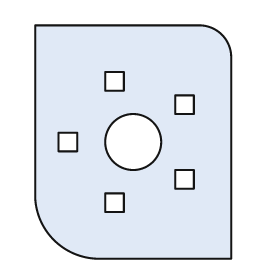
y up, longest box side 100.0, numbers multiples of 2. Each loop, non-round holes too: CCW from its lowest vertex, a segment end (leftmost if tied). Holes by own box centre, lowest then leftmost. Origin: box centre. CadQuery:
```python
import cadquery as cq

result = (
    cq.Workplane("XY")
    .moveTo(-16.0, -50.0)
    .lineTo(42.0, -50.0)
    .lineTo(42.0, 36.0)
    .threePointArc((38.0, 46.0), (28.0, 50.0))
    .lineTo(-42.0, 50.0)
    .lineTo(-42.0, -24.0)
    .threePointArc((-34.0, -42.0), (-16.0, -50.0))
    .close()
    .moveTo(-12.0, -30.0)
    .lineTo(-4.0, -30.0)
    .lineTo(-4.0, -22.0)
    .lineTo(-12.0, -22.0)
    .close()
    .moveTo(18.0, -20.0)
    .lineTo(26.0, -20.0)
    .lineTo(26.0, -12.0)
    .lineTo(18.0, -12.0)
    .close()
    .moveTo(-32.0, -4.0)
    .lineTo(-24.0, -4.0)
    .lineTo(-24.0, 4.0)
    .lineTo(-32.0, 4.0)
    .close()
    .moveTo(0.0, 0.0)
    .circle(12.0)
    .moveTo(18.0, 12.0)
    .lineTo(26.0, 12.0)
    .lineTo(26.0, 20.0)
    .lineTo(18.0, 20.0)
    .close()
    .moveTo(-12.0, 22.0)
    .lineTo(-4.0, 22.0)
    .lineTo(-4.0, 30.0)
    .lineTo(-12.0, 30.0)
    .close()
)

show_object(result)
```